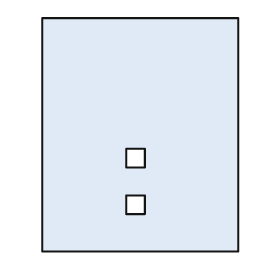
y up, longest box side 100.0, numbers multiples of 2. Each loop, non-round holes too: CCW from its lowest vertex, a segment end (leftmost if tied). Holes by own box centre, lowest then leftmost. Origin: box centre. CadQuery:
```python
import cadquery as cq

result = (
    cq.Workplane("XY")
    .moveTo(-42.0, -50.0)
    .lineTo(42.0, -50.0)
    .lineTo(42.0, 50.0)
    .lineTo(-42.0, 50.0)
    .close()
    .moveTo(-6.0, -34.0)
    .lineTo(2.0, -34.0)
    .lineTo(2.0, -26.0)
    .lineTo(-6.0, -26.0)
    .close()
    .moveTo(-6.0, -14.0)
    .lineTo(2.0, -14.0)
    .lineTo(2.0, -6.0)
    .lineTo(-6.0, -6.0)
    .close()
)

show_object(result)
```